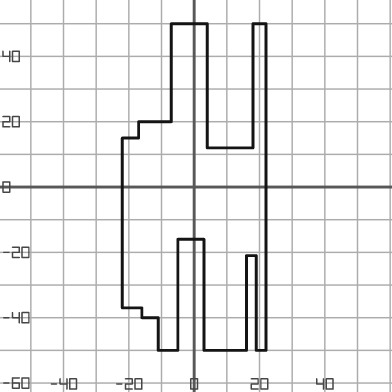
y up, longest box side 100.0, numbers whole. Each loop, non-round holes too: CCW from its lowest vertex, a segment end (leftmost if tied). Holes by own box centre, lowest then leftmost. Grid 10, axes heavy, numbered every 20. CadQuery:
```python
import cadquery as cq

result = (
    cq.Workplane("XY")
    .moveTo(-11.0, -50.0)
    .lineTo(-5.0, -50.0)
    .lineTo(-5.0, -16.0)
    .lineTo(3.0, -16.0)
    .lineTo(3.0, -50.0)
    .lineTo(16.0, -50.0)
    .lineTo(16.0, -21.0)
    .lineTo(19.0, -21.0)
    .lineTo(19.0, -50.0)
    .lineTo(22.0, -50.0)
    .lineTo(22.0, 50.0)
    .lineTo(18.0, 50.0)
    .lineTo(18.0, 12.0)
    .lineTo(4.0, 12.0)
    .lineTo(4.0, 50.0)
    .lineTo(-7.0, 50.0)
    .lineTo(-7.0, 20.0)
    .lineTo(-17.0, 20.0)
    .lineTo(-17.0, 15.0)
    .lineTo(-22.0, 15.0)
    .lineTo(-22.0, -37.0)
    .lineTo(-16.0, -37.0)
    .lineTo(-16.0, -40.0)
    .lineTo(-11.0, -40.0)
    .close()
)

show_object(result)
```